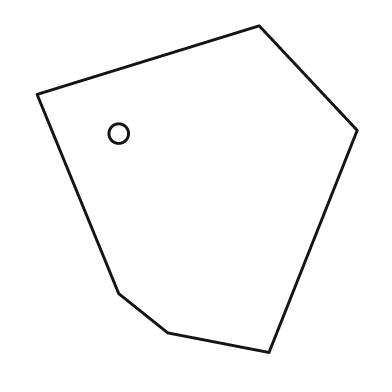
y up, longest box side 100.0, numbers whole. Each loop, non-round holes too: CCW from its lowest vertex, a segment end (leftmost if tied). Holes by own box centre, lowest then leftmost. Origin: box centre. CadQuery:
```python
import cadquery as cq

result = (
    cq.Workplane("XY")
    .moveTo(22.0, -50.0)
    .lineTo(49.0, 18.0)
    .lineTo(19.0, 50.0)
    .lineTo(-49.0, 29.0)
    .lineTo(-24.0, -32.0)
    .lineTo(-9.0, -44.0)
    .close()
    .moveTo(-24.0, 17.0)
    .circle(3.0)
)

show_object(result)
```